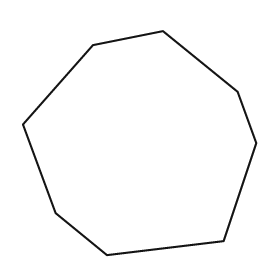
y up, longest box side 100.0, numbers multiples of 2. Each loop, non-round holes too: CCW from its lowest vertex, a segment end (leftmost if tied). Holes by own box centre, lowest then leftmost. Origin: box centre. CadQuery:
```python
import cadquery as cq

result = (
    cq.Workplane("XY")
    .moveTo(-14.0, -48.0)
    .lineTo(36.0, -42.0)
    .lineTo(50.0, 0.0)
    .lineTo(42.0, 22.0)
    .lineTo(10.0, 48.0)
    .lineTo(-20.0, 42.0)
    .lineTo(-50.0, 8.0)
    .lineTo(-36.0, -30.0)
    .close()
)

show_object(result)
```